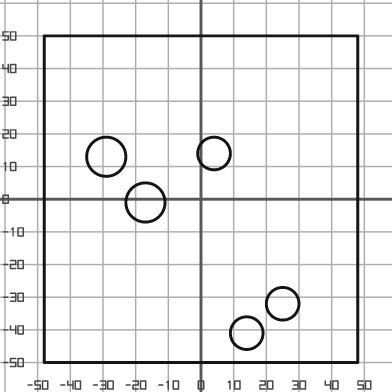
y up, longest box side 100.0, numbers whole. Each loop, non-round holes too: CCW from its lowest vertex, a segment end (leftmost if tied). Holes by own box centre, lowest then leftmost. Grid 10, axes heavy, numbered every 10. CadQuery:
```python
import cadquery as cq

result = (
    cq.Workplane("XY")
    .moveTo(-48.0, -50.0)
    .lineTo(48.0, -50.0)
    .lineTo(48.0, 50.0)
    .lineTo(-48.0, 50.0)
    .close()
    .moveTo(14.0, -41.0)
    .circle(5.0)
    .moveTo(25.0, -32.0)
    .circle(5.0)
    .moveTo(-17.0, -1.0)
    .circle(6.0)
    .moveTo(-29.0, 13.0)
    .circle(6.0)
    .moveTo(4.0, 14.0)
    .circle(5.0)
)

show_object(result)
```